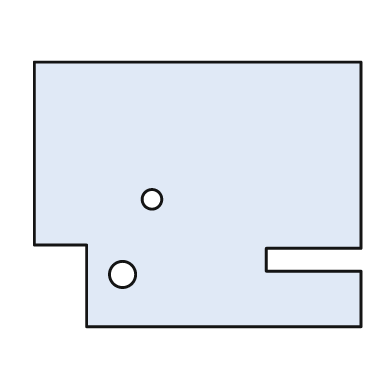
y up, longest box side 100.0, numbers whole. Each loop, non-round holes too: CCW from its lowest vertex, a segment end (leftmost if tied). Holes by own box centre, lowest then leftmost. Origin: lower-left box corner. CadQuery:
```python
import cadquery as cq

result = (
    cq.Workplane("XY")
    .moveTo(16.0, 0.0)
    .lineTo(100.0, 0.0)
    .lineTo(100.0, 17.0)
    .lineTo(71.0, 17.0)
    .lineTo(71.0, 24.0)
    .lineTo(100.0, 24.0)
    .lineTo(100.0, 81.0)
    .lineTo(0.0, 81.0)
    .lineTo(0.0, 25.0)
    .lineTo(16.0, 25.0)
    .close()
    .moveTo(27.0, 16.0)
    .circle(4.0)
    .moveTo(36.0, 39.0)
    .circle(3.0)
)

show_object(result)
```